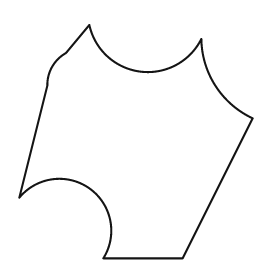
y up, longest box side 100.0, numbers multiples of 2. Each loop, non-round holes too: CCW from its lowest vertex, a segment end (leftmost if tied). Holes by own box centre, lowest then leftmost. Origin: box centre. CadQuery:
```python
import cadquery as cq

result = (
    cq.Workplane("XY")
    .moveTo(-14.0, -50.0)
    .lineTo(20.0, -50.0)
    .lineTo(50.0, 10.0)
    .threePointArc((34.0, 24.0), (28.0, 44.0))
    .threePointArc((2.0, 30.0), (-20.0, 50.0))
    .lineTo(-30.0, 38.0)
    .threePointArc((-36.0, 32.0), (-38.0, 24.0))
    .lineTo(-50.0, -24.0)
    .threePointArc((-20.0, -20.0), (-14.0, -50.0))
    .close()
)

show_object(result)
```